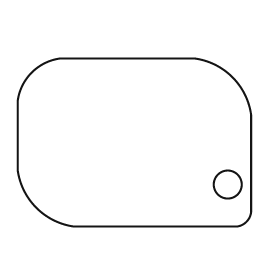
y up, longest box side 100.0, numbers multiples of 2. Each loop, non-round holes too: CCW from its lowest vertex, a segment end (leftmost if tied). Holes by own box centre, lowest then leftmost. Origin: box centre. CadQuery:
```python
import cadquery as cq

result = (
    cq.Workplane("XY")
    .moveTo(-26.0, -36.0)
    .lineTo(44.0, -36.0)
    .threePointArc((48.0, -34.0), (50.0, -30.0))
    .lineTo(50.0, 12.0)
    .threePointArc((42.0, 28.0), (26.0, 36.0))
    .lineTo(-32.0, 36.0)
    .threePointArc((-44.0, 30.0), (-50.0, 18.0))
    .lineTo(-50.0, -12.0)
    .threePointArc((-42.0, -28.0), (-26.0, -36.0))
    .close()
    .moveTo(40.0, -18.0)
    .circle(6.0)
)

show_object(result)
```